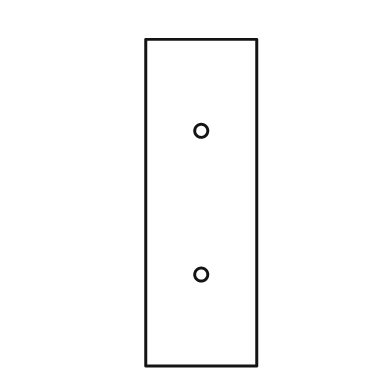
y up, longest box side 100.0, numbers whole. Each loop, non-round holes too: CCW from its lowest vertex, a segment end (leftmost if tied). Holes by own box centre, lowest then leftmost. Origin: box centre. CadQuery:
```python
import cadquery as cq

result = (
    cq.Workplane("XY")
    .moveTo(-17.0, -50.0)
    .lineTo(17.0, -50.0)
    .lineTo(17.0, 50.0)
    .lineTo(-17.0, 50.0)
    .close()
    .moveTo(0.0, -22.0)
    .circle(2.0)
    .moveTo(0.0, 22.0)
    .circle(2.0)
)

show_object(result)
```